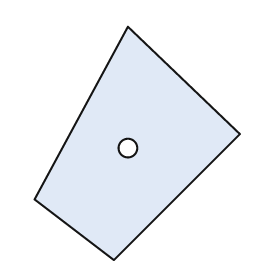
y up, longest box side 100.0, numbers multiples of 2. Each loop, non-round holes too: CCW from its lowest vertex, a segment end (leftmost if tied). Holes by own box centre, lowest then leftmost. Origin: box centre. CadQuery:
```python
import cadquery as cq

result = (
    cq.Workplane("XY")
    .moveTo(-10.0, -50.0)
    .lineTo(44.0, 4.0)
    .lineTo(-4.0, 50.0)
    .lineTo(-44.0, -24.0)
    .close()
    .moveTo(-4.0, -2.0)
    .circle(4.0)
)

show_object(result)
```